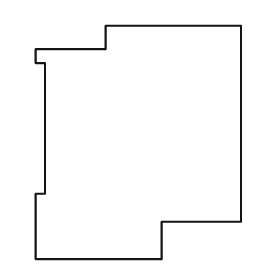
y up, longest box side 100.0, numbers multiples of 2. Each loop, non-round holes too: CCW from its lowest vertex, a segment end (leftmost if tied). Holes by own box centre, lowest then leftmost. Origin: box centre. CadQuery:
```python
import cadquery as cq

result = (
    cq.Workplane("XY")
    .moveTo(-44.0, -50.0)
    .lineTo(10.0, -50.0)
    .lineTo(10.0, -34.0)
    .lineTo(44.0, -34.0)
    .lineTo(44.0, 50.0)
    .lineTo(-14.0, 50.0)
    .lineTo(-14.0, 40.0)
    .lineTo(-44.0, 40.0)
    .lineTo(-44.0, 34.0)
    .lineTo(-40.0, 34.0)
    .lineTo(-40.0, -22.0)
    .lineTo(-44.0, -22.0)
    .close()
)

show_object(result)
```